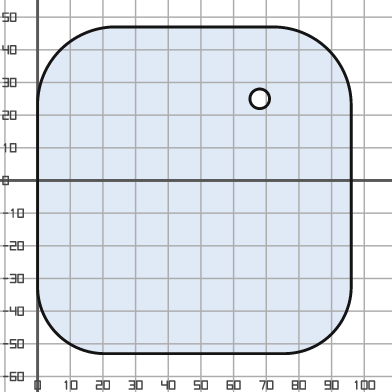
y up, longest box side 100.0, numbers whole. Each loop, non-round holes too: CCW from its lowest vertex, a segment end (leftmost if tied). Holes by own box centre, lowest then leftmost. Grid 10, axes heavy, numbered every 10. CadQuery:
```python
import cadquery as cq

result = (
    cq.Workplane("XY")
    .moveTo(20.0, -53.0)
    .lineTo(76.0, -53.0)
    .threePointArc((90.0, -47.0), (96.0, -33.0))
    .lineTo(96.0, 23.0)
    .threePointArc((89.0, 40.0), (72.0, 47.0))
    .lineTo(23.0, 47.0)
    .threePointArc((7.0, 40.0), (0.0, 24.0))
    .lineTo(0.0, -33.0)
    .threePointArc((6.0, -47.0), (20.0, -53.0))
    .close()
    .moveTo(68.0, 25.0)
    .circle(3.0)
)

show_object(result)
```